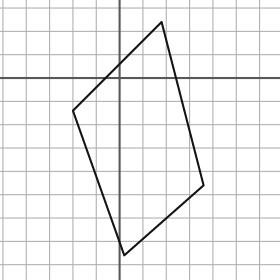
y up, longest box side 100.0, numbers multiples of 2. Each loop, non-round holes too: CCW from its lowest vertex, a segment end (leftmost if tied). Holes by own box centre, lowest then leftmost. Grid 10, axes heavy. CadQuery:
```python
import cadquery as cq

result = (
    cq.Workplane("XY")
    .moveTo(2.0, -76.0)
    .lineTo(36.0, -46.0)
    .lineTo(18.0, 24.0)
    .lineTo(-20.0, -14.0)
    .close()
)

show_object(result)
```